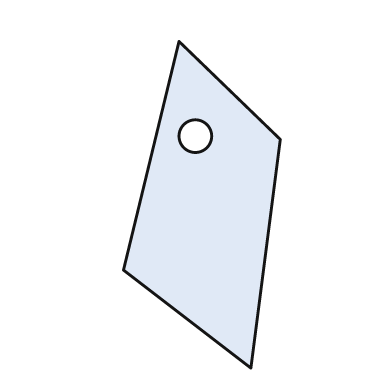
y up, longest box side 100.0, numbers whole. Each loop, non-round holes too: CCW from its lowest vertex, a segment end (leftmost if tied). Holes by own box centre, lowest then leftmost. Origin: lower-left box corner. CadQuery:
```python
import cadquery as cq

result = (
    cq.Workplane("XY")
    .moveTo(39.0, 0.0)
    .lineTo(48.0, 70.0)
    .lineTo(17.0, 100.0)
    .lineTo(0.0, 30.0)
    .close()
    .moveTo(22.0, 71.0)
    .circle(5.0)
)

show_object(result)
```